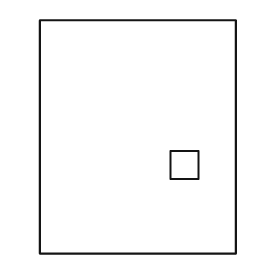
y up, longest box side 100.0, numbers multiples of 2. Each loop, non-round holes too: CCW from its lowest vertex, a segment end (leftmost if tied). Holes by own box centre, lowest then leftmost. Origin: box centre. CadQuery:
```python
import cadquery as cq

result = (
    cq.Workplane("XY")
    .moveTo(-42.0, -50.0)
    .lineTo(42.0, -50.0)
    .lineTo(42.0, 50.0)
    .lineTo(-42.0, 50.0)
    .close()
    .moveTo(14.0, -18.0)
    .lineTo(26.0, -18.0)
    .lineTo(26.0, -6.0)
    .lineTo(14.0, -6.0)
    .close()
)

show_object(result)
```